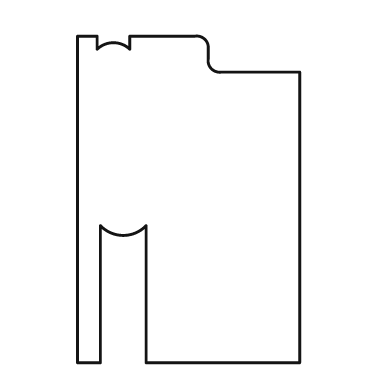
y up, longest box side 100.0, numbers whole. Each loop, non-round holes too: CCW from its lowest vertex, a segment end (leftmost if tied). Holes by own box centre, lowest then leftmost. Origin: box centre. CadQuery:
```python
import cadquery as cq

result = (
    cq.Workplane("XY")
    .moveTo(-34.0, -50.0)
    .lineTo(-27.0, -50.0)
    .lineTo(-27.0, -8.0)
    .threePointArc((-20.0, -11.0), (-13.0, -8.0))
    .lineTo(-13.0, -50.0)
    .lineTo(34.0, -50.0)
    .lineTo(34.0, 39.0)
    .lineTo(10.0, 39.0)
    .threePointArc((7.0, 40.0), (6.0, 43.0))
    .lineTo(6.0, 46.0)
    .threePointArc((5.0, 49.0), (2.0, 50.0))
    .lineTo(-18.0, 50.0)
    .lineTo(-18.0, 46.0)
    .threePointArc((-23.0, 48.0), (-28.0, 46.0))
    .lineTo(-28.0, 50.0)
    .lineTo(-34.0, 50.0)
    .close()
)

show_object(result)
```